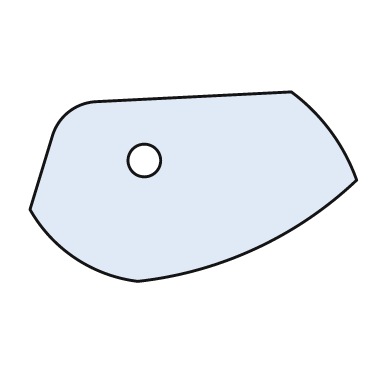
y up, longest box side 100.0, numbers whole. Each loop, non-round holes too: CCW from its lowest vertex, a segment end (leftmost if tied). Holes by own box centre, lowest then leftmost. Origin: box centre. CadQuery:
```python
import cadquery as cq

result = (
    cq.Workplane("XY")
    .moveTo(-17.0, -29.0)
    .threePointArc((19.0, -19.0), (50.0, 2.0))
    .threePointArc((42.0, 17.0), (30.0, 29.0))
    .lineTo(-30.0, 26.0)
    .threePointArc((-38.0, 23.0), (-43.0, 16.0))
    .lineTo(-50.0, -7.0)
    .threePointArc((-36.0, -22.0), (-17.0, -29.0))
    .close()
    .moveTo(-15.0, 8.0)
    .circle(5.0)
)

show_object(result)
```